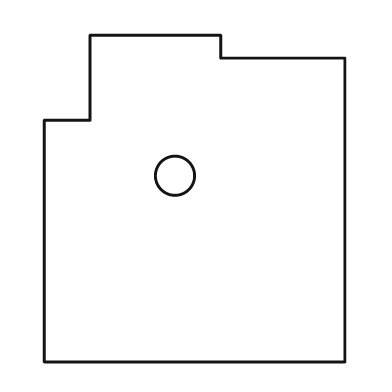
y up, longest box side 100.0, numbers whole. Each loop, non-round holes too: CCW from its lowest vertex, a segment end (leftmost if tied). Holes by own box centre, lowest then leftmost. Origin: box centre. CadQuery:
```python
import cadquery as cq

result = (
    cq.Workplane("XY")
    .moveTo(-46.0, -50.0)
    .lineTo(46.0, -50.0)
    .lineTo(46.0, 43.0)
    .lineTo(8.0, 43.0)
    .lineTo(8.0, 50.0)
    .lineTo(-32.0, 50.0)
    .lineTo(-32.0, 24.0)
    .lineTo(-46.0, 24.0)
    .close()
    .moveTo(-6.0, 7.0)
    .circle(6.0)
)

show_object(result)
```